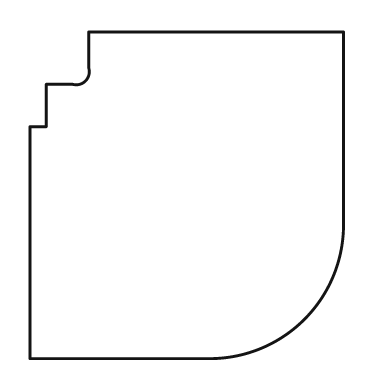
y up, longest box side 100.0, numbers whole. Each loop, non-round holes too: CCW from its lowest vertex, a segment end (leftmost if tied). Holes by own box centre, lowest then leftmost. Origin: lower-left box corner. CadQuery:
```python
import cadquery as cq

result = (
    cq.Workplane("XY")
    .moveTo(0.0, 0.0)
    .lineTo(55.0, 0.0)
    .threePointArc((84.0, 12.0), (96.0, 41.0))
    .lineTo(96.0, 100.0)
    .lineTo(18.0, 100.0)
    .lineTo(18.0, 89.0)
    .threePointArc((17.0, 85.0), (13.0, 84.0))
    .lineTo(5.0, 84.0)
    .lineTo(5.0, 71.0)
    .lineTo(0.0, 71.0)
    .close()
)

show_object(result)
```